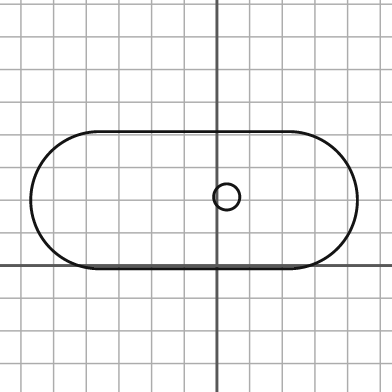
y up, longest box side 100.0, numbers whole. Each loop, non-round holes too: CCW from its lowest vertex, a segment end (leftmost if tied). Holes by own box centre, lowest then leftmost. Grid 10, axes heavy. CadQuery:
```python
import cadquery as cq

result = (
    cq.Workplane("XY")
    .moveTo(-36.0, -1.0)
    .lineTo(22.0, -1.0)
    .threePointArc((43.0, 20.0), (22.0, 41.0))
    .lineTo(-36.0, 41.0)
    .threePointArc((-57.0, 20.0), (-36.0, -1.0))
    .close()
    .moveTo(3.0, 21.0)
    .circle(4.0)
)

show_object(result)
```